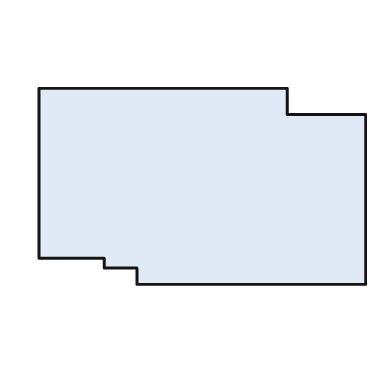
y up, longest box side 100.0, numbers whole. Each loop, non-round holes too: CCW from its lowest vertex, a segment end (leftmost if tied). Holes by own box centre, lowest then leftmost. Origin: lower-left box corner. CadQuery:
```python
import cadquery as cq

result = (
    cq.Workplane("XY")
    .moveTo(30.0, 0.0)
    .lineTo(100.0, 0.0)
    .lineTo(100.0, 52.0)
    .lineTo(76.0, 52.0)
    .lineTo(76.0, 60.0)
    .lineTo(0.0, 60.0)
    .lineTo(0.0, 8.0)
    .lineTo(20.0, 8.0)
    .lineTo(20.0, 5.0)
    .lineTo(30.0, 5.0)
    .close()
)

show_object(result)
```